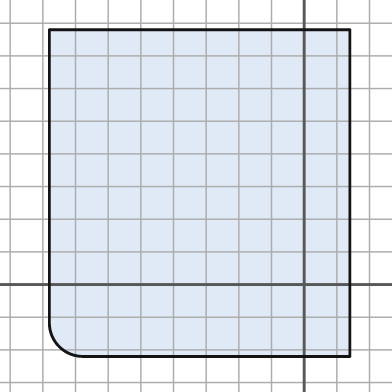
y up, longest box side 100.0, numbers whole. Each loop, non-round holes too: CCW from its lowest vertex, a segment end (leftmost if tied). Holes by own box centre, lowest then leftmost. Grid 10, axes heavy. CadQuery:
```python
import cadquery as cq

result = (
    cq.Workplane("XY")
    .moveTo(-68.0, -22.0)
    .lineTo(14.0, -22.0)
    .lineTo(14.0, 78.0)
    .lineTo(-78.0, 78.0)
    .lineTo(-78.0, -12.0)
    .threePointArc((-75.0, -19.0), (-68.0, -22.0))
    .close()
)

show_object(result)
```